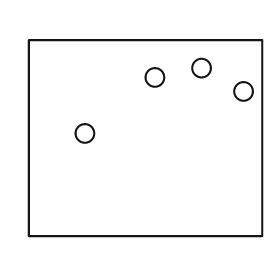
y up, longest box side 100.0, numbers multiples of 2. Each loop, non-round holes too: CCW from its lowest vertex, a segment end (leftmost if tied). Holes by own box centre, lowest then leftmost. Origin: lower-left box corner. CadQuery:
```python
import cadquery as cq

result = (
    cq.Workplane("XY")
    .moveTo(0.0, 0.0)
    .lineTo(100.0, 0.0)
    .lineTo(100.0, 84.0)
    .lineTo(0.0, 84.0)
    .close()
    .moveTo(24.0, 44.0)
    .circle(4.0)
    .moveTo(92.0, 62.0)
    .circle(4.0)
    .moveTo(54.0, 68.0)
    .circle(4.0)
    .moveTo(74.0, 72.0)
    .circle(4.0)
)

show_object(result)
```